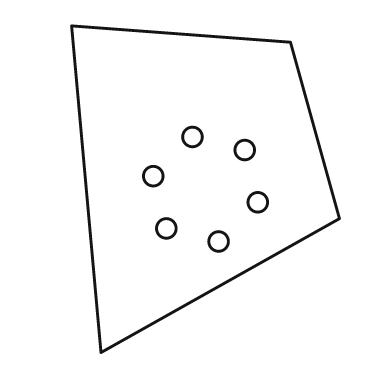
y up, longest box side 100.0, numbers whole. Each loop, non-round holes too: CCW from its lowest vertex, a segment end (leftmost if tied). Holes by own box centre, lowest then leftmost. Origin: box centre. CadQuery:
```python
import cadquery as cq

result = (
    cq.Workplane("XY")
    .moveTo(-32.0, -50.0)
    .lineTo(41.0, -9.0)
    .lineTo(26.0, 45.0)
    .lineTo(-41.0, 50.0)
    .close()
    .moveTo(4.0, -16.0)
    .circle(3.0)
    .moveTo(-12.0, -12.0)
    .circle(3.0)
    .moveTo(16.0, -4.0)
    .circle(3.0)
    .moveTo(-16.0, 4.0)
    .circle(3.0)
    .moveTo(12.0, 12.0)
    .circle(3.0)
    .moveTo(-4.0, 16.0)
    .circle(3.0)
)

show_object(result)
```